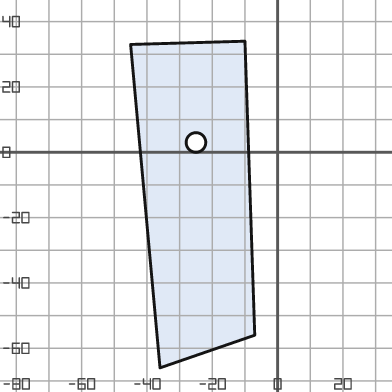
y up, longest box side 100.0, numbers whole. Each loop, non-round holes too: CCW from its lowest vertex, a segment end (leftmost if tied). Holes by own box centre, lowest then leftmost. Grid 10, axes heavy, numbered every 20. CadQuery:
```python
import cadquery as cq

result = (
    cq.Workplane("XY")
    .moveTo(-36.0, -66.0)
    .lineTo(-7.0, -56.0)
    .lineTo(-10.0, 34.0)
    .lineTo(-45.0, 33.0)
    .close()
    .moveTo(-25.0, 3.0)
    .circle(3.0)
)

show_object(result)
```